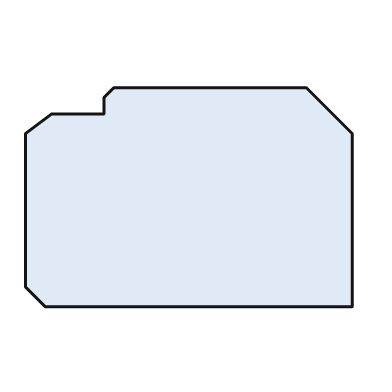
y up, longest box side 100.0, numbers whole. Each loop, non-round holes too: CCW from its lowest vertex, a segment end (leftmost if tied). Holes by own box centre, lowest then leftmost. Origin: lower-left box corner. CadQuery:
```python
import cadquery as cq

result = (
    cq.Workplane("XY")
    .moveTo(6.0, 0.0)
    .lineTo(100.0, 0.0)
    .lineTo(100.0, 53.0)
    .lineTo(86.0, 67.0)
    .lineTo(27.0, 67.0)
    .lineTo(24.0, 64.0)
    .lineTo(24.0, 59.0)
    .lineTo(8.0, 59.0)
    .lineTo(0.0, 53.0)
    .lineTo(0.0, 6.0)
    .close()
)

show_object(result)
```